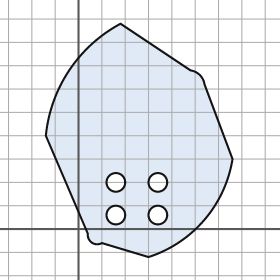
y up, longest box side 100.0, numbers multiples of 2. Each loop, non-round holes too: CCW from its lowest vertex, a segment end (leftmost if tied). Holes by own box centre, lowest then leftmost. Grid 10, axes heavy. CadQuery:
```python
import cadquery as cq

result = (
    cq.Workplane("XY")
    .moveTo(30.0, -12.0)
    .threePointArc((54.0, 4.0), (66.0, 30.0))
    .lineTo(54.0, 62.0)
    .threePointArc((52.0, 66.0), (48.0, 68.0))
    .lineTo(18.0, 88.0)
    .threePointArc((-4.0, 68.0), (-14.0, 40.0))
    .lineTo(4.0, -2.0)
    .threePointArc((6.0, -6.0), (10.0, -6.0))
    .close()
    .moveTo(16.0, 6.0)
    .circle(4.0)
    .moveTo(34.0, 6.0)
    .circle(4.0)
    .moveTo(16.0, 20.0)
    .circle(4.0)
    .moveTo(34.0, 20.0)
    .circle(4.0)
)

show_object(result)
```